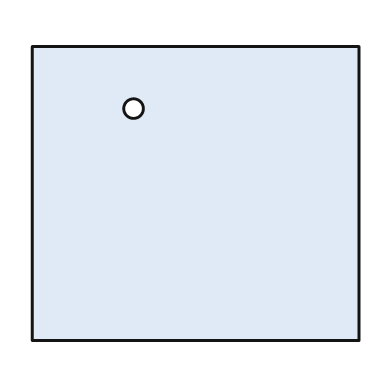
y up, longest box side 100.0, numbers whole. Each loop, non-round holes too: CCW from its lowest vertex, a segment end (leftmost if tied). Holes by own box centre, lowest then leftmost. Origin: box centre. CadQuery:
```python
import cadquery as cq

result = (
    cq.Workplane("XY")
    .moveTo(-50.0, -45.0)
    .lineTo(50.0, -45.0)
    .lineTo(50.0, 45.0)
    .lineTo(-50.0, 45.0)
    .close()
    .moveTo(-19.0, 26.0)
    .circle(3.0)
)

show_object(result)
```